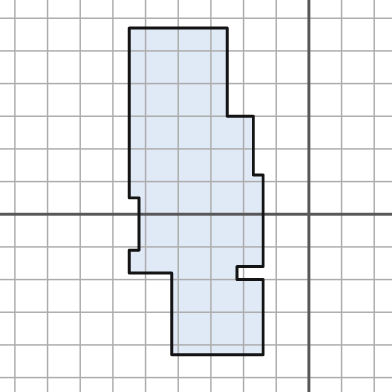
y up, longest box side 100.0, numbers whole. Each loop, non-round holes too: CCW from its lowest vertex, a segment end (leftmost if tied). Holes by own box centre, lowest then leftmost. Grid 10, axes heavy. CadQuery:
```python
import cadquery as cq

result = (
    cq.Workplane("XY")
    .moveTo(-42.0, -43.0)
    .lineTo(-14.0, -43.0)
    .lineTo(-14.0, -20.0)
    .lineTo(-22.0, -20.0)
    .lineTo(-22.0, -16.0)
    .lineTo(-14.0, -16.0)
    .lineTo(-14.0, 12.0)
    .lineTo(-17.0, 12.0)
    .lineTo(-17.0, 30.0)
    .lineTo(-25.0, 30.0)
    .lineTo(-25.0, 57.0)
    .lineTo(-55.0, 57.0)
    .lineTo(-55.0, 5.0)
    .lineTo(-52.0, 5.0)
    .lineTo(-52.0, -11.0)
    .lineTo(-55.0, -11.0)
    .lineTo(-55.0, -18.0)
    .lineTo(-42.0, -18.0)
    .close()
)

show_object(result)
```